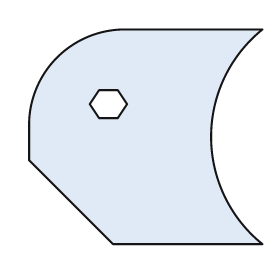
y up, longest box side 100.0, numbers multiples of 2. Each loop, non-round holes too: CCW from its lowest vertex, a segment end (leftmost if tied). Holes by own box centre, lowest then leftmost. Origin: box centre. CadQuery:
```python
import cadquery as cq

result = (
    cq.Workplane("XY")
    .moveTo(-14.0, -46.0)
    .lineTo(50.0, -46.0)
    .threePointArc((28.0, 0.0), (50.0, 46.0))
    .lineTo(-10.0, 46.0)
    .threePointArc((-38.0, 34.0), (-50.0, 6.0))
    .lineTo(-50.0, -10.0)
    .close()
    .moveTo(-20.0, 8.0)
    .lineTo(-12.0, 8.0)
    .lineTo(-8.0, 14.0)
    .lineTo(-12.0, 20.0)
    .lineTo(-20.0, 20.0)
    .lineTo(-24.0, 14.0)
    .close()
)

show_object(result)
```